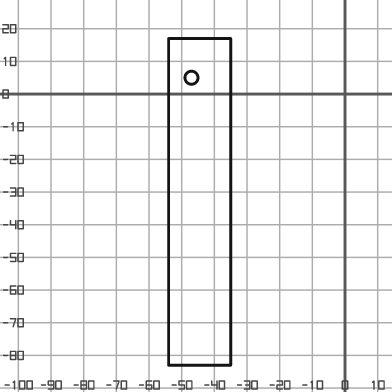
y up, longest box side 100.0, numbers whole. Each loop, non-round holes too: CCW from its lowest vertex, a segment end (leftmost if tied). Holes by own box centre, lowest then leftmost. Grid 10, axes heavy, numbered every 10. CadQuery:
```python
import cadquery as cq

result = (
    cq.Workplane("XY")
    .moveTo(-54.0, -83.0)
    .lineTo(-35.0, -83.0)
    .lineTo(-35.0, 17.0)
    .lineTo(-54.0, 17.0)
    .close()
    .moveTo(-47.0, 5.0)
    .circle(2.0)
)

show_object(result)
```